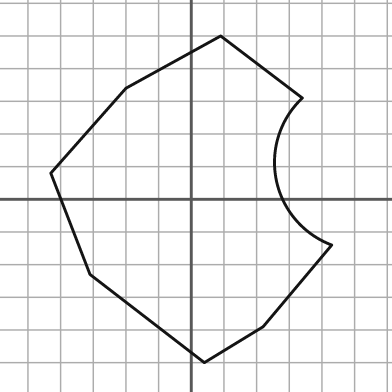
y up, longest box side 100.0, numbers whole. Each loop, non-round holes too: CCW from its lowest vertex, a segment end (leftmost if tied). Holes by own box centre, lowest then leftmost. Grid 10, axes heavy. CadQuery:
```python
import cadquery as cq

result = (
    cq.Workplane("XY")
    .moveTo(4.0, -50.0)
    .lineTo(22.0, -39.0)
    .lineTo(43.0, -14.0)
    .threePointArc((26.0, 6.0), (34.0, 31.0))
    .lineTo(9.0, 50.0)
    .lineTo(-20.0, 34.0)
    .lineTo(-43.0, 8.0)
    .lineTo(-31.0, -23.0)
    .close()
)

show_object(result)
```